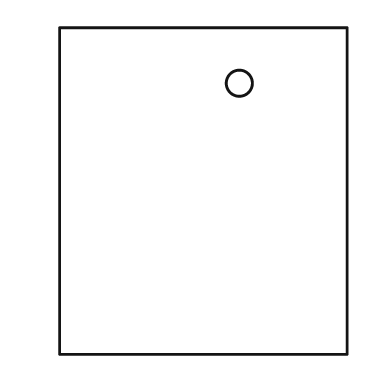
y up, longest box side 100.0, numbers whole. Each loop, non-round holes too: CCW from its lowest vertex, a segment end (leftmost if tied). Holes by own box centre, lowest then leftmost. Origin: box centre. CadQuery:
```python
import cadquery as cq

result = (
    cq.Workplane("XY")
    .moveTo(-44.0, -50.0)
    .lineTo(44.0, -50.0)
    .lineTo(44.0, 50.0)
    .lineTo(-44.0, 50.0)
    .close()
    .moveTo(11.0, 33.0)
    .circle(4.0)
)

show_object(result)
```